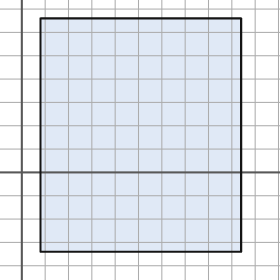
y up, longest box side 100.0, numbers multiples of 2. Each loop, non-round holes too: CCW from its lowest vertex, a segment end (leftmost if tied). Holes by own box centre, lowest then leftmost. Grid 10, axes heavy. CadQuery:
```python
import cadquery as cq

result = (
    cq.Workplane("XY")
    .moveTo(8.0, -34.0)
    .lineTo(94.0, -34.0)
    .lineTo(94.0, 66.0)
    .lineTo(8.0, 66.0)
    .close()
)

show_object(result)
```